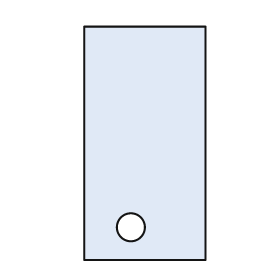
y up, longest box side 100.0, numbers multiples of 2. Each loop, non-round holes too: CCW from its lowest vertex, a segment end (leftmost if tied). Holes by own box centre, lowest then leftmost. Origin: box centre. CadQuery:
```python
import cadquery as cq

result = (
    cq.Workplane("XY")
    .moveTo(-26.0, -50.0)
    .lineTo(26.0, -50.0)
    .lineTo(26.0, 50.0)
    .lineTo(-26.0, 50.0)
    .close()
    .moveTo(-6.0, -36.0)
    .circle(6.0)
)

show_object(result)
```